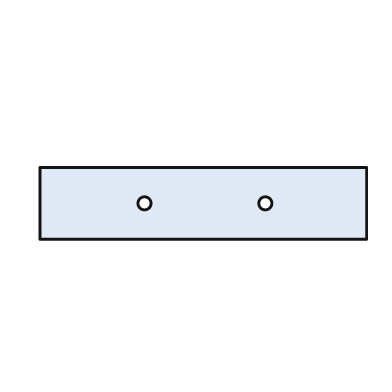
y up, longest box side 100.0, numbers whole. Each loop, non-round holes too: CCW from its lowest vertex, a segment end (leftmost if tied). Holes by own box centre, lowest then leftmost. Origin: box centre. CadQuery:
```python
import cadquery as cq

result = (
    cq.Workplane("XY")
    .moveTo(-50.0, -11.0)
    .lineTo(50.0, -11.0)
    .lineTo(50.0, 11.0)
    .lineTo(-50.0, 11.0)
    .close()
    .moveTo(-18.0, 0.0)
    .circle(2.0)
    .moveTo(19.0, 0.0)
    .circle(2.0)
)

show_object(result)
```